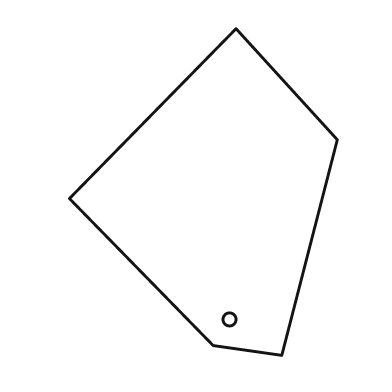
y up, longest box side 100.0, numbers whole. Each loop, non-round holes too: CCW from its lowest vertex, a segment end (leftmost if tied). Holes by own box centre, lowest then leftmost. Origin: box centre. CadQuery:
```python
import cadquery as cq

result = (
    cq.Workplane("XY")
    .moveTo(24.0, -50.0)
    .lineTo(41.0, 16.0)
    .lineTo(10.0, 50.0)
    .lineTo(-41.0, -2.0)
    .lineTo(3.0, -47.0)
    .close()
    .moveTo(8.0, -39.0)
    .circle(2.0)
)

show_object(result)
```